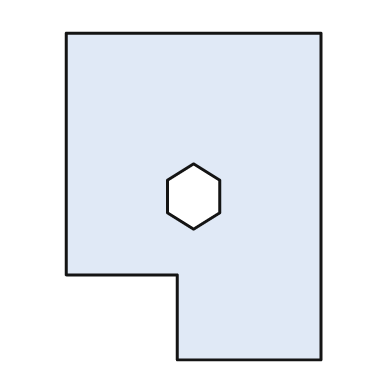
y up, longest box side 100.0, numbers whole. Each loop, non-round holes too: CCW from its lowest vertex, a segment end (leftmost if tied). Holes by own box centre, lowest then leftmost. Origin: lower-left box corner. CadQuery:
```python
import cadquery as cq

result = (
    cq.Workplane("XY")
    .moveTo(34.0, 0.0)
    .lineTo(78.0, 0.0)
    .lineTo(78.0, 100.0)
    .lineTo(0.0, 100.0)
    .lineTo(0.0, 26.0)
    .lineTo(34.0, 26.0)
    .close()
    .moveTo(39.0, 40.0)
    .lineTo(47.0, 45.0)
    .lineTo(47.0, 55.0)
    .lineTo(39.0, 60.0)
    .lineTo(31.0, 55.0)
    .lineTo(31.0, 45.0)
    .close()
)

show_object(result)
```